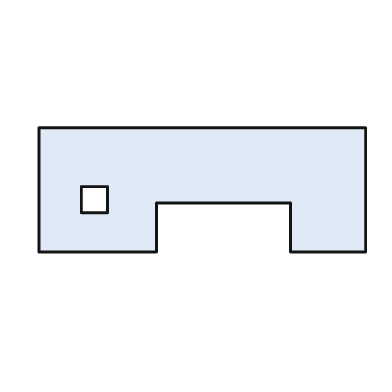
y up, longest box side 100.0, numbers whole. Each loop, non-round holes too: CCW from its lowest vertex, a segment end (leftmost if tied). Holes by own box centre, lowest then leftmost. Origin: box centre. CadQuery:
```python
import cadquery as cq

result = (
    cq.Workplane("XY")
    .moveTo(-50.0, -19.0)
    .lineTo(-14.0, -19.0)
    .lineTo(-14.0, -4.0)
    .lineTo(27.0, -4.0)
    .lineTo(27.0, -19.0)
    .lineTo(50.0, -19.0)
    .lineTo(50.0, 19.0)
    .lineTo(-50.0, 19.0)
    .close()
    .moveTo(-37.0, -7.0)
    .lineTo(-29.0, -7.0)
    .lineTo(-29.0, 1.0)
    .lineTo(-37.0, 1.0)
    .close()
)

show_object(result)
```